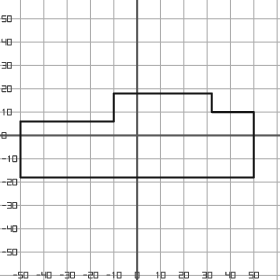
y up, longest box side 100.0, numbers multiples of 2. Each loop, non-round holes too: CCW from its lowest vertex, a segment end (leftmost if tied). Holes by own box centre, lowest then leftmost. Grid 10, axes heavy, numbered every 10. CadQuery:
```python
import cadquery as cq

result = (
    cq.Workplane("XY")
    .moveTo(-50.0, -18.0)
    .lineTo(50.0, -18.0)
    .lineTo(50.0, 10.0)
    .lineTo(32.0, 10.0)
    .lineTo(32.0, 18.0)
    .lineTo(-10.0, 18.0)
    .lineTo(-10.0, 6.0)
    .lineTo(-50.0, 6.0)
    .close()
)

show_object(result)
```